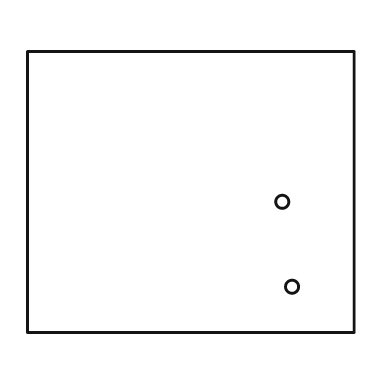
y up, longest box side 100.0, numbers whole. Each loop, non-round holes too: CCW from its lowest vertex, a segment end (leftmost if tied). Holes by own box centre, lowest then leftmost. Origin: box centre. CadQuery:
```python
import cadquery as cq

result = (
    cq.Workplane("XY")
    .moveTo(-50.0, -43.0)
    .lineTo(50.0, -43.0)
    .lineTo(50.0, 43.0)
    .lineTo(-50.0, 43.0)
    .close()
    .moveTo(31.0, -29.0)
    .circle(2.0)
    .moveTo(28.0, -3.0)
    .circle(2.0)
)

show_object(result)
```